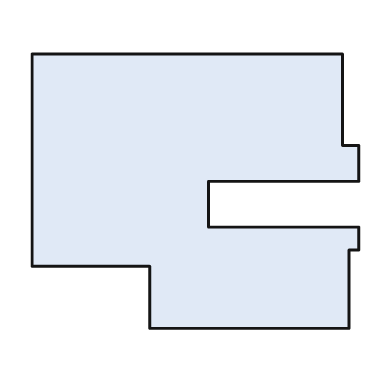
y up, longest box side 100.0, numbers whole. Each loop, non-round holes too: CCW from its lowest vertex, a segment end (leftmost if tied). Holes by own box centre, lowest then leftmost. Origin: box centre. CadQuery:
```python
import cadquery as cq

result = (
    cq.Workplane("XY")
    .moveTo(-14.0, -42.0)
    .lineTo(47.0, -42.0)
    .lineTo(47.0, -18.0)
    .lineTo(50.0, -18.0)
    .lineTo(50.0, -11.0)
    .lineTo(4.0, -11.0)
    .lineTo(4.0, 3.0)
    .lineTo(50.0, 3.0)
    .lineTo(50.0, 14.0)
    .lineTo(45.0, 14.0)
    .lineTo(45.0, 42.0)
    .lineTo(-50.0, 42.0)
    .lineTo(-50.0, -23.0)
    .lineTo(-14.0, -23.0)
    .close()
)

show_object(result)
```